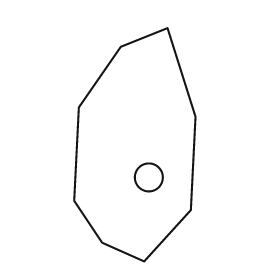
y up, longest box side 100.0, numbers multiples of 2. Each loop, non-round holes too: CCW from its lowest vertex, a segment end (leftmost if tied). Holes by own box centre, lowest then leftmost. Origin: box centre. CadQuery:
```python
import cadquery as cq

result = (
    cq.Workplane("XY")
    .moveTo(4.0, -50.0)
    .lineTo(24.0, -28.0)
    .lineTo(26.0, 12.0)
    .lineTo(14.0, 50.0)
    .lineTo(-6.0, 42.0)
    .lineTo(-24.0, 16.0)
    .lineTo(-26.0, -24.0)
    .lineTo(-14.0, -42.0)
    .close()
    .moveTo(6.0, -14.0)
    .circle(6.0)
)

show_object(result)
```